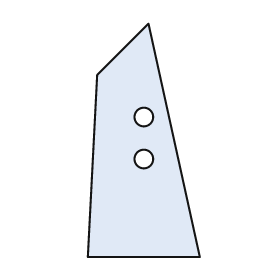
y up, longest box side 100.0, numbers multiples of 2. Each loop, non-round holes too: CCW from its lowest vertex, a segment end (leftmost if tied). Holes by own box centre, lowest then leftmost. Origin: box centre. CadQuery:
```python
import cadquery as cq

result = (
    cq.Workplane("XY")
    .moveTo(-24.0, -50.0)
    .lineTo(24.0, -50.0)
    .lineTo(2.0, 50.0)
    .lineTo(-20.0, 28.0)
    .close()
    .moveTo(0.0, -8.0)
    .circle(4.0)
    .moveTo(0.0, 10.0)
    .circle(4.0)
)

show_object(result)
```